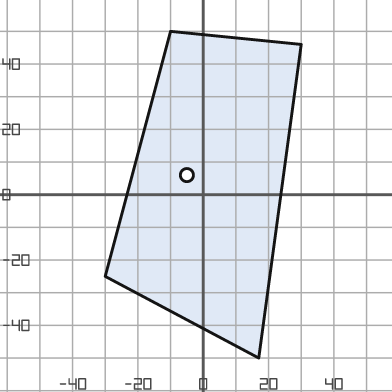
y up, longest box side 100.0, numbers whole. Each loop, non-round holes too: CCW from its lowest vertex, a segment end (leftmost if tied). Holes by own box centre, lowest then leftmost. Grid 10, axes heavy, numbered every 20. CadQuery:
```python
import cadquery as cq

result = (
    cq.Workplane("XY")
    .moveTo(17.0, -50.0)
    .lineTo(30.0, 46.0)
    .lineTo(-10.0, 50.0)
    .lineTo(-30.0, -25.0)
    .close()
    .moveTo(-5.0, 6.0)
    .circle(2.0)
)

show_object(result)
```